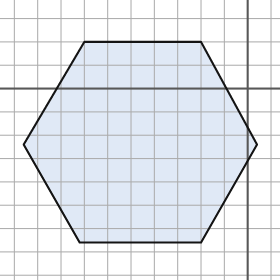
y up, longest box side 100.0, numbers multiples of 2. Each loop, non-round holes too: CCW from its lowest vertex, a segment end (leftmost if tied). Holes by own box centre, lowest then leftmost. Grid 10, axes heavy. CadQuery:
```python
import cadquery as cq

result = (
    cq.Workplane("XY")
    .moveTo(-72.0, -66.0)
    .lineTo(-20.0, -66.0)
    .lineTo(4.0, -24.0)
    .lineTo(-20.0, 20.0)
    .lineTo(-70.0, 20.0)
    .lineTo(-96.0, -24.0)
    .close()
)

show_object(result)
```